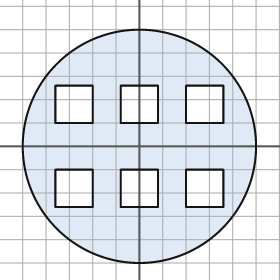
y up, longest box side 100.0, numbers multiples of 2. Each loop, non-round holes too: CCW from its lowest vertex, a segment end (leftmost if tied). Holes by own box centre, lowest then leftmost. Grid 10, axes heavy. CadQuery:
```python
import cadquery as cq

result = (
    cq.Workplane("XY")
    .moveTo(0.0, 0.0)
    .circle(50.0)
    .moveTo(-36.0, -26.0)
    .lineTo(-20.0, -26.0)
    .lineTo(-20.0, -10.0)
    .lineTo(-36.0, -10.0)
    .close()
    .moveTo(-8.0, -26.0)
    .lineTo(8.0, -26.0)
    .lineTo(8.0, -10.0)
    .lineTo(-8.0, -10.0)
    .close()
    .moveTo(20.0, -26.0)
    .lineTo(36.0, -26.0)
    .lineTo(36.0, -10.0)
    .lineTo(20.0, -10.0)
    .close()
    .moveTo(-36.0, 10.0)
    .lineTo(-20.0, 10.0)
    .lineTo(-20.0, 26.0)
    .lineTo(-36.0, 26.0)
    .close()
    .moveTo(-8.0, 10.0)
    .lineTo(8.0, 10.0)
    .lineTo(8.0, 26.0)
    .lineTo(-8.0, 26.0)
    .close()
    .moveTo(20.0, 10.0)
    .lineTo(36.0, 10.0)
    .lineTo(36.0, 26.0)
    .lineTo(20.0, 26.0)
    .close()
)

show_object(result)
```